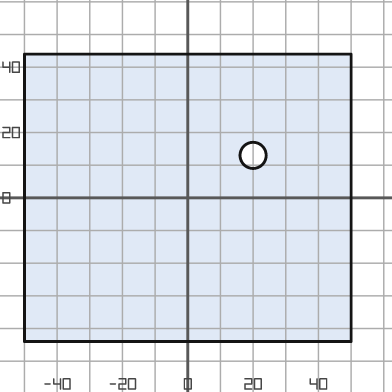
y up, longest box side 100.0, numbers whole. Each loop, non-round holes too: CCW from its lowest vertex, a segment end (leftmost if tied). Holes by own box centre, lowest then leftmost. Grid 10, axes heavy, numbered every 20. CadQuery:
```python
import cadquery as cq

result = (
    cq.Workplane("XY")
    .moveTo(-50.0, -44.0)
    .lineTo(50.0, -44.0)
    .lineTo(50.0, 44.0)
    .lineTo(-50.0, 44.0)
    .close()
    .moveTo(20.0, 13.0)
    .circle(4.0)
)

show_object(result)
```